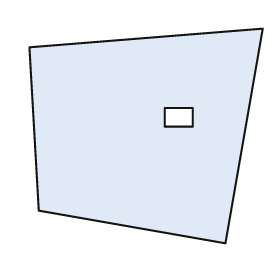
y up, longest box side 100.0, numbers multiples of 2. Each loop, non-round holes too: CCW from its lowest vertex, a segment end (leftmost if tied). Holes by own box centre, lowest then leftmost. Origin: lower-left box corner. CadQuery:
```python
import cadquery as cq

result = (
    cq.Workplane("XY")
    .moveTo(84.0, 0.0)
    .lineTo(100.0, 92.0)
    .lineTo(0.0, 84.0)
    .lineTo(4.0, 14.0)
    .close()
    .moveTo(58.0, 50.0)
    .lineTo(70.0, 50.0)
    .lineTo(70.0, 58.0)
    .lineTo(58.0, 58.0)
    .close()
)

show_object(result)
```